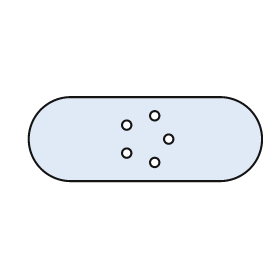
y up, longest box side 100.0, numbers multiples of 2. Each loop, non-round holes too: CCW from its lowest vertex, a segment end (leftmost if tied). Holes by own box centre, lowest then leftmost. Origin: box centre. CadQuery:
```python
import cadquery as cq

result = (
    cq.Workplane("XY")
    .moveTo(-32.0, -18.0)
    .lineTo(32.0, -18.0)
    .threePointArc((50.0, 0.0), (32.0, 18.0))
    .lineTo(-32.0, 18.0)
    .threePointArc((-50.0, 0.0), (-32.0, -18.0))
    .close()
    .moveTo(4.0, -10.0)
    .circle(2.0)
    .moveTo(-8.0, -6.0)
    .circle(2.0)
    .moveTo(10.0, 0.0)
    .circle(2.0)
    .moveTo(-8.0, 6.0)
    .circle(2.0)
    .moveTo(4.0, 10.0)
    .circle(2.0)
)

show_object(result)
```